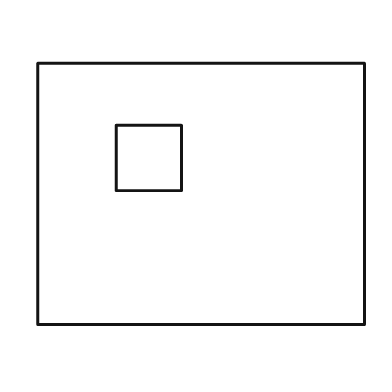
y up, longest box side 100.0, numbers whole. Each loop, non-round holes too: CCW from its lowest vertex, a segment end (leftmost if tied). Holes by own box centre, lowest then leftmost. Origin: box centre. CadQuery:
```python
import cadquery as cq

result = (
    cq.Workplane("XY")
    .moveTo(-50.0, -40.0)
    .lineTo(50.0, -40.0)
    .lineTo(50.0, 40.0)
    .lineTo(-50.0, 40.0)
    .close()
    .moveTo(-26.0, 1.0)
    .lineTo(-6.0, 1.0)
    .lineTo(-6.0, 21.0)
    .lineTo(-26.0, 21.0)
    .close()
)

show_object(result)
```